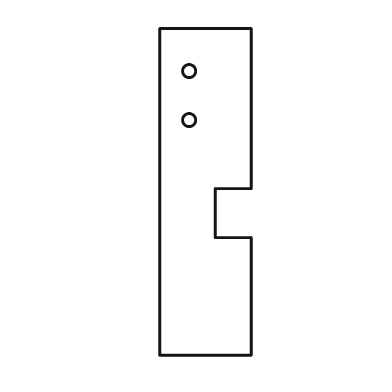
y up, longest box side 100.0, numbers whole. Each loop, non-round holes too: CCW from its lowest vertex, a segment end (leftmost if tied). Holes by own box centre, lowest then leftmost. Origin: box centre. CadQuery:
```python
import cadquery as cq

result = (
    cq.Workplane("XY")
    .moveTo(-14.0, -50.0)
    .lineTo(14.0, -50.0)
    .lineTo(14.0, -14.0)
    .lineTo(3.0, -14.0)
    .lineTo(3.0, 1.0)
    .lineTo(14.0, 1.0)
    .lineTo(14.0, 50.0)
    .lineTo(-14.0, 50.0)
    .close()
    .moveTo(-5.0, 22.0)
    .circle(2.0)
    .moveTo(-5.0, 37.0)
    .circle(2.0)
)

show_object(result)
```